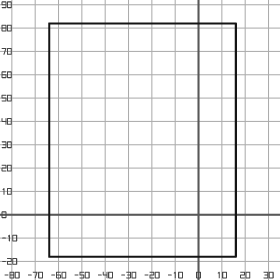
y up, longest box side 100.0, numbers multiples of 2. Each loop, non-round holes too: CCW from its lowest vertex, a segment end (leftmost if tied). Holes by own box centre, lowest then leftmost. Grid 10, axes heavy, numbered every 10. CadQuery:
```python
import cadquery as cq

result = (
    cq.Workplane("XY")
    .moveTo(-64.0, -18.0)
    .lineTo(16.0, -18.0)
    .lineTo(16.0, 82.0)
    .lineTo(-64.0, 82.0)
    .close()
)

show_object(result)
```